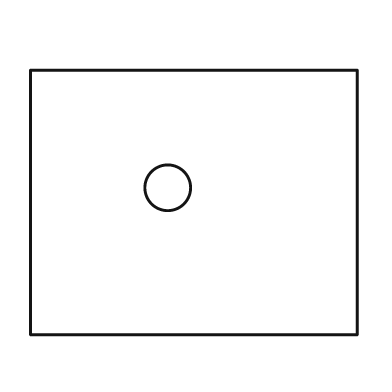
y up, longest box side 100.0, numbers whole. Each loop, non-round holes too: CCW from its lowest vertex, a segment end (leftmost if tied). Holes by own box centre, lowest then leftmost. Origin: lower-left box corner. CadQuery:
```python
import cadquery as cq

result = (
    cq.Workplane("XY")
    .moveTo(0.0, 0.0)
    .lineTo(100.0, 0.0)
    .lineTo(100.0, 81.0)
    .lineTo(0.0, 81.0)
    .close()
    .moveTo(42.0, 45.0)
    .circle(7.0)
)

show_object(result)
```